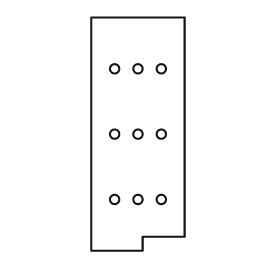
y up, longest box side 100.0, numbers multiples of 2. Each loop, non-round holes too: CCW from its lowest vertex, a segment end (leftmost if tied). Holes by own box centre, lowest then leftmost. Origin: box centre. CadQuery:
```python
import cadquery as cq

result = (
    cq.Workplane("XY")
    .moveTo(-20.0, -50.0)
    .lineTo(2.0, -50.0)
    .lineTo(2.0, -44.0)
    .lineTo(20.0, -44.0)
    .lineTo(20.0, 50.0)
    .lineTo(-20.0, 50.0)
    .close()
    .moveTo(-10.0, -28.0)
    .circle(2.0)
    .moveTo(0.0, -28.0)
    .circle(2.0)
    .moveTo(10.0, -28.0)
    .circle(2.0)
    .moveTo(-10.0, 0.0)
    .circle(2.0)
    .moveTo(0.0, 0.0)
    .circle(2.0)
    .moveTo(10.0, 0.0)
    .circle(2.0)
    .moveTo(-10.0, 28.0)
    .circle(2.0)
    .moveTo(0.0, 28.0)
    .circle(2.0)
    .moveTo(10.0, 28.0)
    .circle(2.0)
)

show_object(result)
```